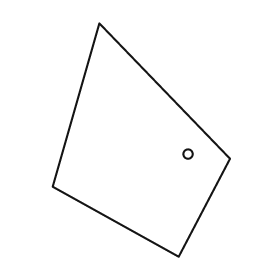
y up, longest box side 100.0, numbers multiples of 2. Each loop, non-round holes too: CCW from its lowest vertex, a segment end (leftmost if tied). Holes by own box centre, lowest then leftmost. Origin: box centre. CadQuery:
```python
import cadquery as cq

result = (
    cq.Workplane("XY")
    .moveTo(16.0, -50.0)
    .lineTo(38.0, -8.0)
    .lineTo(-18.0, 50.0)
    .lineTo(-38.0, -20.0)
    .close()
    .moveTo(20.0, -6.0)
    .circle(2.0)
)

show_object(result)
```